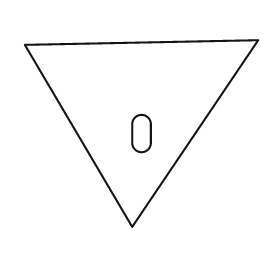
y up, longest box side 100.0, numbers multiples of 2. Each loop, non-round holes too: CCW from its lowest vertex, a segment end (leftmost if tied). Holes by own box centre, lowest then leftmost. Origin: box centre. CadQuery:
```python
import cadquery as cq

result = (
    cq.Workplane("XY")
    .moveTo(-4.0, -40.0)
    .lineTo(50.0, 40.0)
    .lineTo(-50.0, 38.0)
    .close()
    .moveTo(-4.0, -4.0)
    .threePointArc((0.0, -8.0), (4.0, -4.0))
    .lineTo(4.0, 4.0)
    .threePointArc((0.0, 8.0), (-4.0, 4.0))
    .close()
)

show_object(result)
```